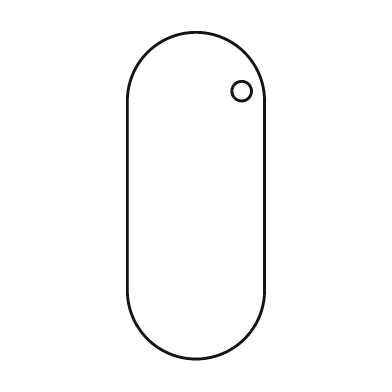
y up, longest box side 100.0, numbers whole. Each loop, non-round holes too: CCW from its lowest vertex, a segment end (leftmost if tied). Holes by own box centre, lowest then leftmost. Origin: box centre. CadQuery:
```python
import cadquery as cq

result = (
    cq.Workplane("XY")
    .moveTo(-21.0, -29.0)
    .threePointArc((0.0, -50.0), (21.0, -29.0))
    .lineTo(21.0, 29.0)
    .threePointArc((0.0, 50.0), (-21.0, 29.0))
    .close()
    .moveTo(14.0, 32.0)
    .circle(3.0)
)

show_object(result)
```